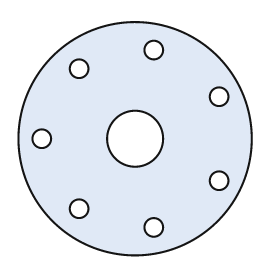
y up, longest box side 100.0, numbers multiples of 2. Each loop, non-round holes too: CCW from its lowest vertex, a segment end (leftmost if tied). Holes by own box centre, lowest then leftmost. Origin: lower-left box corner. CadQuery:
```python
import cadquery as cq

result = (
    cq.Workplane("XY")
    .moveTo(50.0, 50.0)
    .circle(50.0)
    .moveTo(58.0, 12.0)
    .circle(4.0)
    .moveTo(26.0, 20.0)
    .circle(4.0)
    .moveTo(86.0, 32.0)
    .circle(4.0)
    .moveTo(10.0, 50.0)
    .circle(4.0)
    .moveTo(50.0, 50.0)
    .circle(12.0)
    .moveTo(86.0, 68.0)
    .circle(4.0)
    .moveTo(26.0, 80.0)
    .circle(4.0)
    .moveTo(58.0, 88.0)
    .circle(4.0)
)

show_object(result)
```